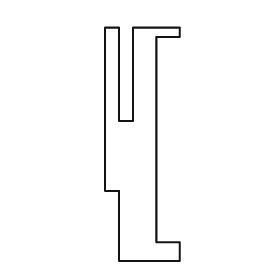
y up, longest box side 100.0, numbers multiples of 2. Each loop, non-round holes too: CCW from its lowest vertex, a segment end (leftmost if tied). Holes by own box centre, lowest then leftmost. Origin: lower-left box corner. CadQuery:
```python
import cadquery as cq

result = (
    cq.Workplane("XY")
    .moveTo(6.0, 0.0)
    .lineTo(32.0, 0.0)
    .lineTo(32.0, 8.0)
    .lineTo(22.0, 8.0)
    .lineTo(22.0, 96.0)
    .lineTo(32.0, 96.0)
    .lineTo(32.0, 100.0)
    .lineTo(12.0, 100.0)
    .lineTo(12.0, 60.0)
    .lineTo(6.0, 60.0)
    .lineTo(6.0, 100.0)
    .lineTo(0.0, 100.0)
    .lineTo(0.0, 30.0)
    .lineTo(6.0, 30.0)
    .close()
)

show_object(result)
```